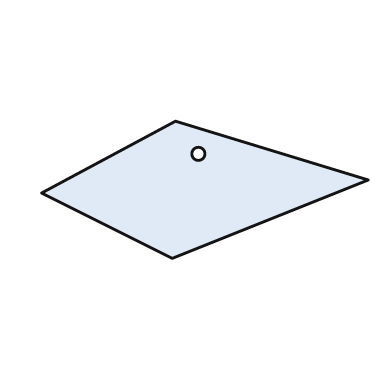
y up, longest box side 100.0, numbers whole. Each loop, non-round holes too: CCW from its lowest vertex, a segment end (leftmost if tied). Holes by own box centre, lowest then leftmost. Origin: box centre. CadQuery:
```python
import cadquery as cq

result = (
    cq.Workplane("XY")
    .moveTo(-10.0, -21.0)
    .lineTo(50.0, 3.0)
    .lineTo(-9.0, 21.0)
    .lineTo(-50.0, -1.0)
    .close()
    .moveTo(-2.0, 11.0)
    .circle(2.0)
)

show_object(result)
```